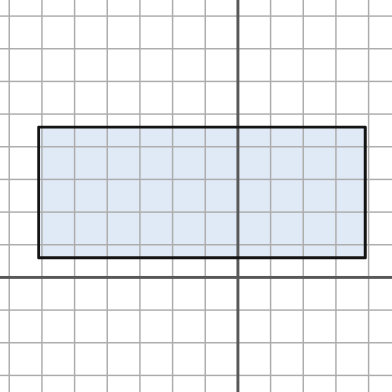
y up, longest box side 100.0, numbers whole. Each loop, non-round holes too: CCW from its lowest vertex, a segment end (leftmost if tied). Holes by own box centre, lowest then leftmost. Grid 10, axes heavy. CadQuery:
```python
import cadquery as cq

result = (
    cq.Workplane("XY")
    .moveTo(-61.0, 6.0)
    .lineTo(39.0, 6.0)
    .lineTo(39.0, 46.0)
    .lineTo(-61.0, 46.0)
    .close()
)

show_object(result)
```